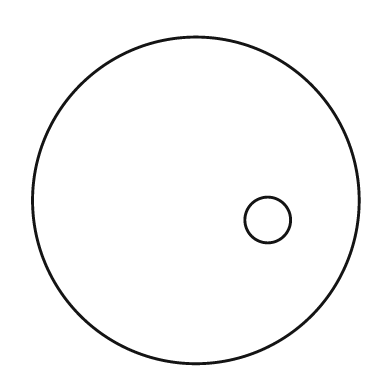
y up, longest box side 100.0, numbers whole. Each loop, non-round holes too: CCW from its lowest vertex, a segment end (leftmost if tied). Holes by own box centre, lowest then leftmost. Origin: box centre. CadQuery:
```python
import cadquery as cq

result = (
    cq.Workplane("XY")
    .moveTo(0.0, 0.0)
    .circle(50.0)
    .moveTo(22.0, -6.0)
    .circle(7.0)
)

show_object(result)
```